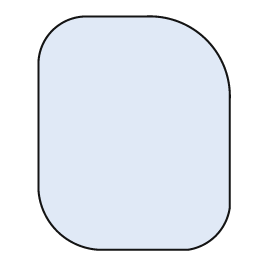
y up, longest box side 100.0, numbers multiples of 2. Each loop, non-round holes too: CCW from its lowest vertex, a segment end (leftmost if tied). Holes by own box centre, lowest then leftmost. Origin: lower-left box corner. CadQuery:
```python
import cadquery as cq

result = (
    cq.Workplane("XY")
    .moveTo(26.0, 0.0)
    .lineTo(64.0, 0.0)
    .threePointArc((76.0, 6.0), (82.0, 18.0))
    .lineTo(82.0, 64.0)
    .threePointArc((72.0, 90.0), (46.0, 100.0))
    .lineTo(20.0, 100.0)
    .threePointArc((6.0, 94.0), (0.0, 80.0))
    .lineTo(0.0, 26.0)
    .threePointArc((8.0, 8.0), (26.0, 0.0))
    .close()
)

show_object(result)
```